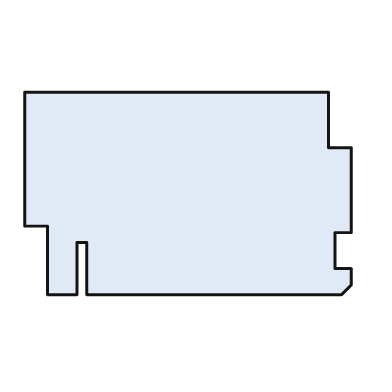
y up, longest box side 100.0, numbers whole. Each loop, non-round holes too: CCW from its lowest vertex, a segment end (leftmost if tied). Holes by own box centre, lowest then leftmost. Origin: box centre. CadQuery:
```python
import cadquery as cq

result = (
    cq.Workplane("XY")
    .moveTo(-43.0, -31.0)
    .lineTo(-34.0, -31.0)
    .lineTo(-34.0, -15.0)
    .lineTo(-31.0, -15.0)
    .lineTo(-31.0, -31.0)
    .lineTo(47.0, -31.0)
    .lineTo(50.0, -28.0)
    .lineTo(50.0, -23.0)
    .lineTo(45.0, -23.0)
    .lineTo(45.0, -12.0)
    .lineTo(50.0, -12.0)
    .lineTo(50.0, 14.0)
    .lineTo(43.0, 14.0)
    .lineTo(43.0, 31.0)
    .lineTo(-50.0, 31.0)
    .lineTo(-50.0, -10.0)
    .lineTo(-43.0, -10.0)
    .close()
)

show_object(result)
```